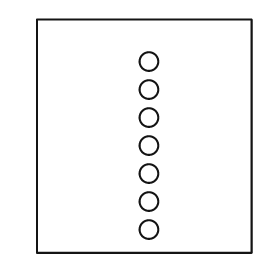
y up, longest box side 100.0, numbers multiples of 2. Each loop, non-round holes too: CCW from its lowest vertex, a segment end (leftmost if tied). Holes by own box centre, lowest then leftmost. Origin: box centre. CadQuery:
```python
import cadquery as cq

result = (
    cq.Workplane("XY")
    .moveTo(-46.0, -50.0)
    .lineTo(46.0, -50.0)
    .lineTo(46.0, 50.0)
    .lineTo(-46.0, 50.0)
    .close()
    .moveTo(2.0, -40.0)
    .circle(4.0)
    .moveTo(2.0, -28.0)
    .circle(4.0)
    .moveTo(2.0, -16.0)
    .circle(4.0)
    .moveTo(2.0, -4.0)
    .circle(4.0)
    .moveTo(2.0, 8.0)
    .circle(4.0)
    .moveTo(2.0, 20.0)
    .circle(4.0)
    .moveTo(2.0, 32.0)
    .circle(4.0)
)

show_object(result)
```